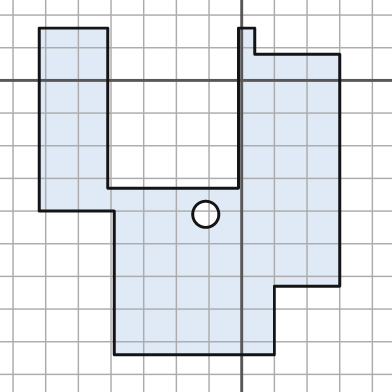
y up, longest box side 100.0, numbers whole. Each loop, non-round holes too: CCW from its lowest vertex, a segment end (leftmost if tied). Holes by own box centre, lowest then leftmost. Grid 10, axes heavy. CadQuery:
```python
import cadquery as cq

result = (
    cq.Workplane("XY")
    .moveTo(-39.0, -84.0)
    .lineTo(10.0, -84.0)
    .lineTo(10.0, -63.0)
    .lineTo(30.0, -63.0)
    .lineTo(30.0, 8.0)
    .lineTo(4.0, 8.0)
    .lineTo(4.0, 16.0)
    .lineTo(-1.0, 16.0)
    .lineTo(-1.0, -33.0)
    .lineTo(-41.0, -33.0)
    .lineTo(-41.0, 16.0)
    .lineTo(-62.0, 16.0)
    .lineTo(-62.0, -40.0)
    .lineTo(-39.0, -40.0)
    .close()
    .moveTo(-11.0, -41.0)
    .circle(4.0)
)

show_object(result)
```